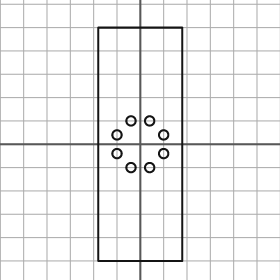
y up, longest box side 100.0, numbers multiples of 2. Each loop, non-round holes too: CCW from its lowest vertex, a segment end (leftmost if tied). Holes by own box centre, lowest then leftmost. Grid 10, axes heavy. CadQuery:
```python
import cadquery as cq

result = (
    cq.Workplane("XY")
    .moveTo(-18.0, -50.0)
    .lineTo(18.0, -50.0)
    .lineTo(18.0, 50.0)
    .lineTo(-18.0, 50.0)
    .close()
    .moveTo(-4.0, -10.0)
    .circle(2.0)
    .moveTo(4.0, -10.0)
    .circle(2.0)
    .moveTo(-10.0, -4.0)
    .circle(2.0)
    .moveTo(10.0, -4.0)
    .circle(2.0)
    .moveTo(-10.0, 4.0)
    .circle(2.0)
    .moveTo(10.0, 4.0)
    .circle(2.0)
    .moveTo(-4.0, 10.0)
    .circle(2.0)
    .moveTo(4.0, 10.0)
    .circle(2.0)
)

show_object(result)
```